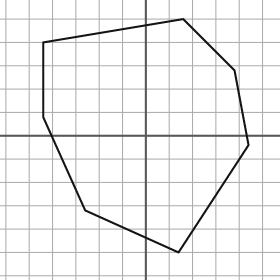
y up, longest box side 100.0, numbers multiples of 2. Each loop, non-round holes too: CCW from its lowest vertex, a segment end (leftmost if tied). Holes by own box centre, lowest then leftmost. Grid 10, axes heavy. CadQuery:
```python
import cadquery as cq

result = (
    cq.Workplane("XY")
    .moveTo(14.0, -50.0)
    .lineTo(44.0, -4.0)
    .lineTo(38.0, 28.0)
    .lineTo(16.0, 50.0)
    .lineTo(-44.0, 40.0)
    .lineTo(-44.0, 8.0)
    .lineTo(-26.0, -32.0)
    .close()
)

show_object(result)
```